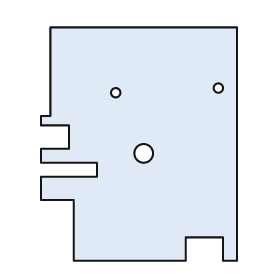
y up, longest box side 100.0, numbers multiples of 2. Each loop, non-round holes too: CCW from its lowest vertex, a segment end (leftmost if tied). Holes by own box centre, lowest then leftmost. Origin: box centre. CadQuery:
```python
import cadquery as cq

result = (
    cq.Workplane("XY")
    .moveTo(-28.0, -50.0)
    .lineTo(20.0, -50.0)
    .lineTo(20.0, -40.0)
    .lineTo(36.0, -40.0)
    .lineTo(36.0, -50.0)
    .lineTo(42.0, -50.0)
    .lineTo(42.0, 50.0)
    .lineTo(-38.0, 50.0)
    .lineTo(-38.0, 12.0)
    .lineTo(-42.0, 12.0)
    .lineTo(-42.0, 8.0)
    .lineTo(-30.0, 8.0)
    .lineTo(-30.0, -2.0)
    .lineTo(-42.0, -2.0)
    .lineTo(-42.0, -8.0)
    .lineTo(-18.0, -8.0)
    .lineTo(-18.0, -14.0)
    .lineTo(-42.0, -14.0)
    .lineTo(-42.0, -24.0)
    .lineTo(-28.0, -24.0)
    .close()
    .moveTo(2.0, -4.0)
    .circle(4.0)
    .moveTo(-10.0, 22.0)
    .circle(2.0)
    .moveTo(34.0, 24.0)
    .circle(2.0)
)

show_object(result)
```